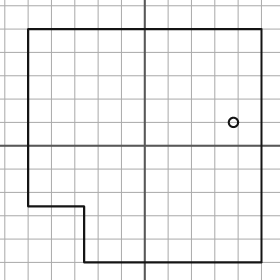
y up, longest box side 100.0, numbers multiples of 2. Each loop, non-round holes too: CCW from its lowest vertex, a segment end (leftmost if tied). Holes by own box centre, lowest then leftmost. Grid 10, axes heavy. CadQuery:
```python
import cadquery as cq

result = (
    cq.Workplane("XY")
    .moveTo(-26.0, -50.0)
    .lineTo(50.0, -50.0)
    .lineTo(50.0, 50.0)
    .lineTo(-50.0, 50.0)
    .lineTo(-50.0, -26.0)
    .lineTo(-26.0, -26.0)
    .close()
    .moveTo(38.0, 10.0)
    .circle(2.0)
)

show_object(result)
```